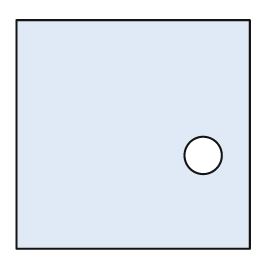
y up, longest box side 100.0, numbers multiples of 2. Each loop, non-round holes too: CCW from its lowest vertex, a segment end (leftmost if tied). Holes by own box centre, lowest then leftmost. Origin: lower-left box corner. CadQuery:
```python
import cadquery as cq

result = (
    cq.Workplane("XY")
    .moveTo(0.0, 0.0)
    .lineTo(100.0, 0.0)
    .lineTo(100.0, 98.0)
    .lineTo(0.0, 98.0)
    .close()
    .moveTo(80.0, 40.0)
    .circle(8.0)
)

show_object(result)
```